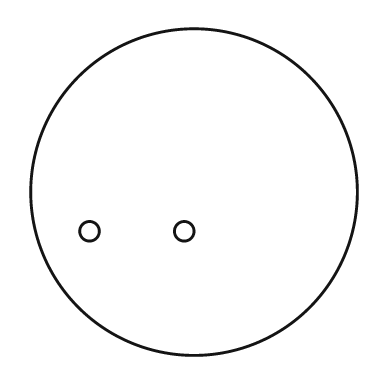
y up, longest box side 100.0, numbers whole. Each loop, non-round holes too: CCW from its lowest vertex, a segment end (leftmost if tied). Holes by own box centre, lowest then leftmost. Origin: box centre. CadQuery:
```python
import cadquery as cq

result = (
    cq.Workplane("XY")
    .moveTo(0.0, 0.0)
    .circle(50.0)
    .moveTo(-32.0, -12.0)
    .circle(3.0)
    .moveTo(-3.0, -12.0)
    .circle(3.0)
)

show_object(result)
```